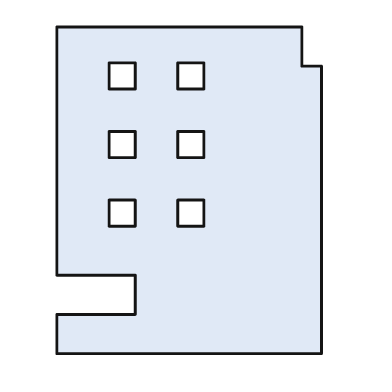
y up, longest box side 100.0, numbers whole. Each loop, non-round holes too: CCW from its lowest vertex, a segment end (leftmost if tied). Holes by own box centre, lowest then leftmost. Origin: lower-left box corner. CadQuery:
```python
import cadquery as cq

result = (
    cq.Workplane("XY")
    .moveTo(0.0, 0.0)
    .lineTo(81.0, 0.0)
    .lineTo(81.0, 88.0)
    .lineTo(75.0, 88.0)
    .lineTo(75.0, 100.0)
    .lineTo(0.0, 100.0)
    .lineTo(0.0, 24.0)
    .lineTo(24.0, 24.0)
    .lineTo(24.0, 12.0)
    .lineTo(0.0, 12.0)
    .close()
    .moveTo(16.0, 39.0)
    .lineTo(24.0, 39.0)
    .lineTo(24.0, 47.0)
    .lineTo(16.0, 47.0)
    .close()
    .moveTo(37.0, 39.0)
    .lineTo(45.0, 39.0)
    .lineTo(45.0, 47.0)
    .lineTo(37.0, 47.0)
    .close()
    .moveTo(16.0, 60.0)
    .lineTo(24.0, 60.0)
    .lineTo(24.0, 68.0)
    .lineTo(16.0, 68.0)
    .close()
    .moveTo(37.0, 60.0)
    .lineTo(45.0, 60.0)
    .lineTo(45.0, 68.0)
    .lineTo(37.0, 68.0)
    .close()
    .moveTo(16.0, 81.0)
    .lineTo(24.0, 81.0)
    .lineTo(24.0, 89.0)
    .lineTo(16.0, 89.0)
    .close()
    .moveTo(37.0, 81.0)
    .lineTo(45.0, 81.0)
    .lineTo(45.0, 89.0)
    .lineTo(37.0, 89.0)
    .close()
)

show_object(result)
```